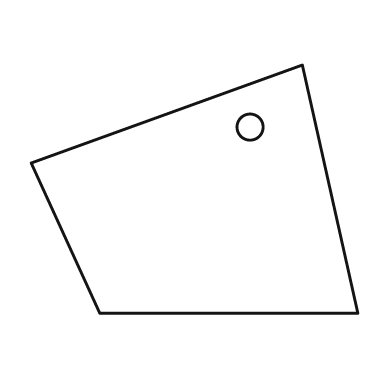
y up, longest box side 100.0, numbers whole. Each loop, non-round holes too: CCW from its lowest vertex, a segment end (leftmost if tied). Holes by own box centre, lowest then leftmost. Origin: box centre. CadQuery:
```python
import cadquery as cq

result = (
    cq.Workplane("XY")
    .moveTo(-29.0, -38.0)
    .lineTo(50.0, -38.0)
    .lineTo(33.0, 38.0)
    .lineTo(-50.0, 8.0)
    .close()
    .moveTo(17.0, 19.0)
    .circle(4.0)
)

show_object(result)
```